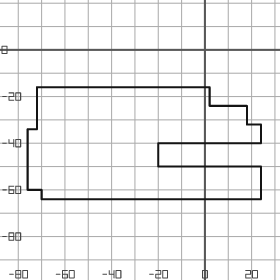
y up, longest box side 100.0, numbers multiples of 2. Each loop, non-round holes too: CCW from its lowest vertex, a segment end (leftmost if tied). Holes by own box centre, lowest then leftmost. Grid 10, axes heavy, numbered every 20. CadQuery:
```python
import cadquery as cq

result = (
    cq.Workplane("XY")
    .moveTo(-70.0, -64.0)
    .lineTo(24.0, -64.0)
    .lineTo(24.0, -50.0)
    .lineTo(-20.0, -50.0)
    .lineTo(-20.0, -40.0)
    .lineTo(24.0, -40.0)
    .lineTo(24.0, -32.0)
    .lineTo(18.0, -32.0)
    .lineTo(18.0, -24.0)
    .lineTo(2.0, -24.0)
    .lineTo(2.0, -16.0)
    .lineTo(-72.0, -16.0)
    .lineTo(-72.0, -34.0)
    .lineTo(-76.0, -34.0)
    .lineTo(-76.0, -60.0)
    .lineTo(-70.0, -60.0)
    .close()
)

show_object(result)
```